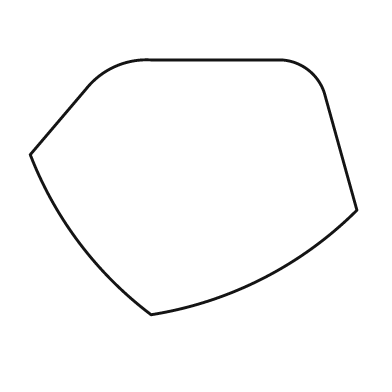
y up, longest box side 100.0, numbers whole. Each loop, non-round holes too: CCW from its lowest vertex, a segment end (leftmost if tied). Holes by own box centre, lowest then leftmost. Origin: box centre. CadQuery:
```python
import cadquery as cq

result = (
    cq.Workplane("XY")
    .moveTo(-13.0, -39.0)
    .threePointArc((21.0, -28.0), (50.0, -7.0))
    .lineTo(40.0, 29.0)
    .threePointArc((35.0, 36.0), (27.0, 39.0))
    .lineTo(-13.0, 39.0)
    .threePointArc((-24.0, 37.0), (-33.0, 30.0))
    .lineTo(-50.0, 10.0)
    .threePointArc((-35.0, -17.0), (-13.0, -39.0))
    .close()
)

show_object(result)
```